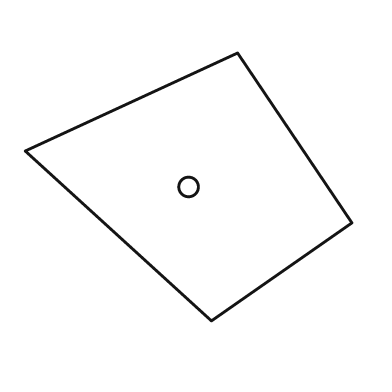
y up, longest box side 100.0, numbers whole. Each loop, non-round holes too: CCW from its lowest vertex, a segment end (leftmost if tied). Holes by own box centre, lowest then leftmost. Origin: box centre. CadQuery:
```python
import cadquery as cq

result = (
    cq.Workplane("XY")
    .moveTo(7.0, -41.0)
    .lineTo(50.0, -11.0)
    .lineTo(15.0, 41.0)
    .lineTo(-50.0, 11.0)
    .close()
    .moveTo(0.0, 0.0)
    .circle(3.0)
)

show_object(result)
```